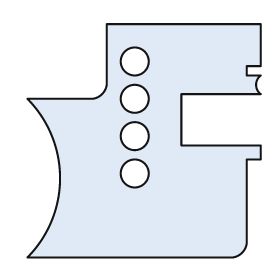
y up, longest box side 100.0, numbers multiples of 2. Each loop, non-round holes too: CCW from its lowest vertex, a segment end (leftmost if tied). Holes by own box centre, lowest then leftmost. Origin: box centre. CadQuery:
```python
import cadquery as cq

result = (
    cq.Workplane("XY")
    .moveTo(-50.0, -50.0)
    .lineTo(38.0, -50.0)
    .threePointArc((42.0, -48.0), (44.0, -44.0))
    .lineTo(44.0, -8.0)
    .lineTo(50.0, -8.0)
    .lineTo(50.0, -2.0)
    .lineTo(16.0, -2.0)
    .lineTo(16.0, 20.0)
    .lineTo(50.0, 20.0)
    .threePointArc((48.0, 24.0), (50.0, 28.0))
    .lineTo(44.0, 28.0)
    .lineTo(44.0, 32.0)
    .lineTo(50.0, 32.0)
    .lineTo(50.0, 50.0)
    .lineTo(-16.0, 50.0)
    .lineTo(-16.0, 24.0)
    .threePointArc((-18.0, 20.0), (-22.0, 18.0))
    .lineTo(-50.0, 18.0)
    .threePointArc((-36.0, -16.0), (-50.0, -50.0))
    .close()
    .moveTo(-4.0, -14.0)
    .circle(6.0)
    .moveTo(-4.0, 2.0)
    .circle(6.0)
    .moveTo(-4.0, 18.0)
    .circle(6.0)
    .moveTo(-4.0, 34.0)
    .circle(6.0)
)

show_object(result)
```